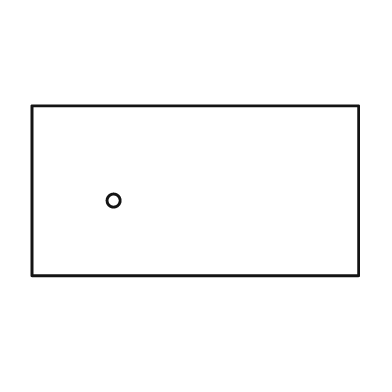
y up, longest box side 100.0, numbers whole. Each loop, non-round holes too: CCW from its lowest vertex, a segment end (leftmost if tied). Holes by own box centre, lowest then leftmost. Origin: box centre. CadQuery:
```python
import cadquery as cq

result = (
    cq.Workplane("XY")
    .moveTo(-50.0, -26.0)
    .lineTo(50.0, -26.0)
    .lineTo(50.0, 26.0)
    .lineTo(-50.0, 26.0)
    .close()
    .moveTo(-25.0, -3.0)
    .circle(2.0)
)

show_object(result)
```